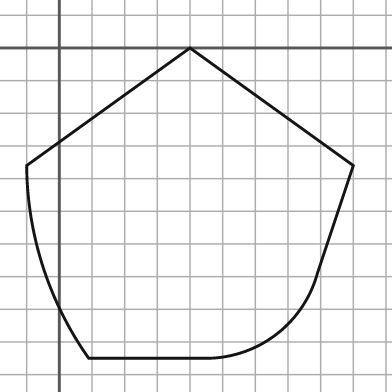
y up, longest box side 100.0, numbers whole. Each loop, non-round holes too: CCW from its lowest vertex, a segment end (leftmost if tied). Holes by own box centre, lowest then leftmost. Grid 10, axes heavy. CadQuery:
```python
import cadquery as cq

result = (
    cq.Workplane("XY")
    .moveTo(9.0, -95.0)
    .lineTo(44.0, -95.0)
    .threePointArc((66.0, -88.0), (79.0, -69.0))
    .lineTo(90.0, -36.0)
    .lineTo(40.0, 0.0)
    .lineTo(-10.0, -36.0)
    .threePointArc((-5.0, -67.0), (9.0, -95.0))
    .close()
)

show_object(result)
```